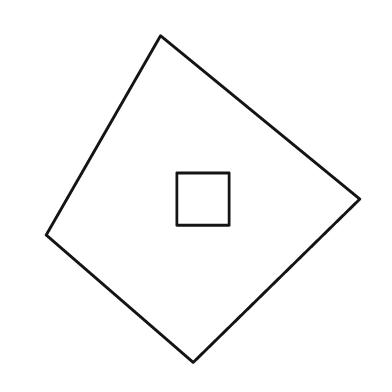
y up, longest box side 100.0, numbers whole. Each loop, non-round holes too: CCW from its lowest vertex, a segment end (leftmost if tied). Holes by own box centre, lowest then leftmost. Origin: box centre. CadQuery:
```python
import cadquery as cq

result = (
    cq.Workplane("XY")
    .moveTo(-3.0, -50.0)
    .lineTo(48.0, 0.0)
    .lineTo(-13.0, 50.0)
    .lineTo(-48.0, -11.0)
    .close()
    .moveTo(-8.0, -8.0)
    .lineTo(8.0, -8.0)
    .lineTo(8.0, 8.0)
    .lineTo(-8.0, 8.0)
    .close()
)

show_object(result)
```